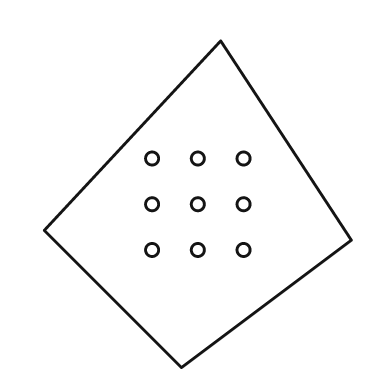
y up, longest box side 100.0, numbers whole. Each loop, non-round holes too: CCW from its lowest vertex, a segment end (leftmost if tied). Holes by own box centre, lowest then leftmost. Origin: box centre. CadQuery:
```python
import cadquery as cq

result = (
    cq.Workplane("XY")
    .moveTo(-5.0, -50.0)
    .lineTo(47.0, -11.0)
    .lineTo(7.0, 50.0)
    .lineTo(-47.0, -8.0)
    .close()
    .moveTo(-14.0, -14.0)
    .circle(2.0)
    .moveTo(0.0, -14.0)
    .circle(2.0)
    .moveTo(14.0, -14.0)
    .circle(2.0)
    .moveTo(-14.0, 0.0)
    .circle(2.0)
    .moveTo(0.0, 0.0)
    .circle(2.0)
    .moveTo(14.0, 0.0)
    .circle(2.0)
    .moveTo(-14.0, 14.0)
    .circle(2.0)
    .moveTo(0.0, 14.0)
    .circle(2.0)
    .moveTo(14.0, 14.0)
    .circle(2.0)
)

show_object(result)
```